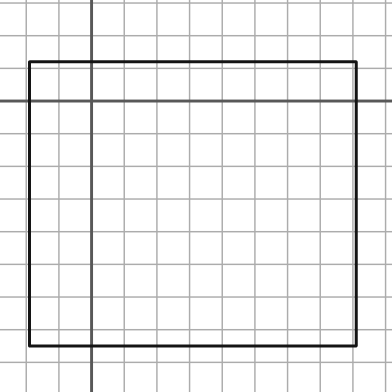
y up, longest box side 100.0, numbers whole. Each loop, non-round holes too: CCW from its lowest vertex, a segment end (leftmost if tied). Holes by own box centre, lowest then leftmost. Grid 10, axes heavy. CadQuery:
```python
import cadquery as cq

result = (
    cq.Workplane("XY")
    .moveTo(-19.0, -75.0)
    .lineTo(81.0, -75.0)
    .lineTo(81.0, 12.0)
    .lineTo(-19.0, 12.0)
    .close()
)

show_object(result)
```